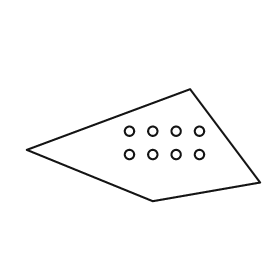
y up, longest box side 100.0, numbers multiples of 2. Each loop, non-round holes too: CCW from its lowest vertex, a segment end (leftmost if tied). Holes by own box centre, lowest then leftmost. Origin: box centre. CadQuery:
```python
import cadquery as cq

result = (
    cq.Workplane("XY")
    .moveTo(4.0, -24.0)
    .lineTo(50.0, -16.0)
    .lineTo(20.0, 24.0)
    .lineTo(-50.0, -2.0)
    .close()
    .moveTo(-6.0, -4.0)
    .circle(2.0)
    .moveTo(4.0, -4.0)
    .circle(2.0)
    .moveTo(14.0, -4.0)
    .circle(2.0)
    .moveTo(24.0, -4.0)
    .circle(2.0)
    .moveTo(-6.0, 6.0)
    .circle(2.0)
    .moveTo(4.0, 6.0)
    .circle(2.0)
    .moveTo(14.0, 6.0)
    .circle(2.0)
    .moveTo(24.0, 6.0)
    .circle(2.0)
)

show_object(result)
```